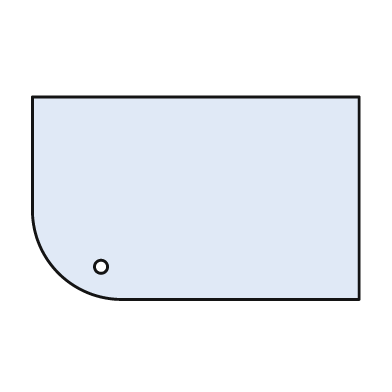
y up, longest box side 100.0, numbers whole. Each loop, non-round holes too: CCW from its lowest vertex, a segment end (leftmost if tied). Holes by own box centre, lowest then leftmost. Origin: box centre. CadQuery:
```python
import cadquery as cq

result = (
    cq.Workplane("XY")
    .moveTo(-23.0, -31.0)
    .lineTo(50.0, -31.0)
    .lineTo(50.0, 31.0)
    .lineTo(-50.0, 31.0)
    .lineTo(-50.0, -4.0)
    .threePointArc((-42.0, -23.0), (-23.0, -31.0))
    .close()
    .moveTo(-29.0, -21.0)
    .circle(2.0)
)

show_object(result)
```